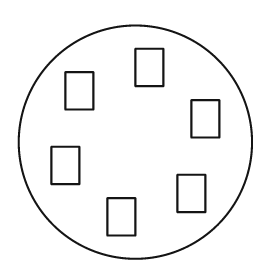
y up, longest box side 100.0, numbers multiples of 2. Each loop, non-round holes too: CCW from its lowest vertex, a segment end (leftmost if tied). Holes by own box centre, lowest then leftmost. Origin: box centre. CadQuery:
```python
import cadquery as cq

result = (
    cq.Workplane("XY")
    .moveTo(0.0, 0.0)
    .circle(50.0)
    .moveTo(-12.0, -40.0)
    .lineTo(0.0, -40.0)
    .lineTo(0.0, -24.0)
    .lineTo(-12.0, -24.0)
    .close()
    .moveTo(18.0, -30.0)
    .lineTo(30.0, -30.0)
    .lineTo(30.0, -14.0)
    .lineTo(18.0, -14.0)
    .close()
    .moveTo(-36.0, -18.0)
    .lineTo(-24.0, -18.0)
    .lineTo(-24.0, -2.0)
    .lineTo(-36.0, -2.0)
    .close()
    .moveTo(24.0, 2.0)
    .lineTo(36.0, 2.0)
    .lineTo(36.0, 18.0)
    .lineTo(24.0, 18.0)
    .close()
    .moveTo(-30.0, 14.0)
    .lineTo(-18.0, 14.0)
    .lineTo(-18.0, 30.0)
    .lineTo(-30.0, 30.0)
    .close()
    .moveTo(0.0, 24.0)
    .lineTo(12.0, 24.0)
    .lineTo(12.0, 40.0)
    .lineTo(0.0, 40.0)
    .close()
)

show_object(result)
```